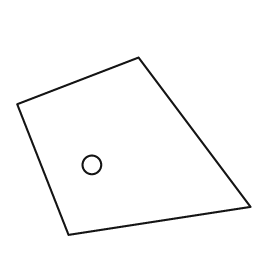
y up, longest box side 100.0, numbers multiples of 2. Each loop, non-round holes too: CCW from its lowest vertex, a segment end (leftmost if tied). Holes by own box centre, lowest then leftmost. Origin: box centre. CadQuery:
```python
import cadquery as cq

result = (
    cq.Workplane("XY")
    .moveTo(-28.0, -38.0)
    .lineTo(50.0, -26.0)
    .lineTo(2.0, 38.0)
    .lineTo(-50.0, 18.0)
    .close()
    .moveTo(-18.0, -8.0)
    .circle(4.0)
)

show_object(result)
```